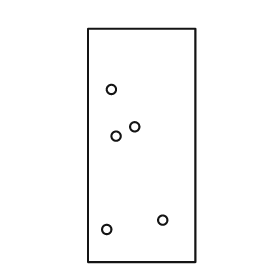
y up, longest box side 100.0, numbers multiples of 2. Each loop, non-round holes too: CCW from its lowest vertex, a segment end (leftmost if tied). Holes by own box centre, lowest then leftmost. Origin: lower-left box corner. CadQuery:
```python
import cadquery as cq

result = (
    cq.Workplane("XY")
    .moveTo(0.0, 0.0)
    .lineTo(46.0, 0.0)
    .lineTo(46.0, 100.0)
    .lineTo(0.0, 100.0)
    .close()
    .moveTo(8.0, 14.0)
    .circle(2.0)
    .moveTo(32.0, 18.0)
    .circle(2.0)
    .moveTo(12.0, 54.0)
    .circle(2.0)
    .moveTo(20.0, 58.0)
    .circle(2.0)
    .moveTo(10.0, 74.0)
    .circle(2.0)
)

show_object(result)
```